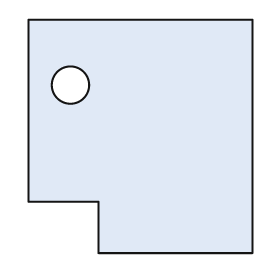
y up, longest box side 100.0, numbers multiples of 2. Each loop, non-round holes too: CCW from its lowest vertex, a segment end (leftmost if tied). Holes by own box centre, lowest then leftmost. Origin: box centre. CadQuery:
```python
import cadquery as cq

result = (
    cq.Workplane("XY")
    .moveTo(-18.0, -50.0)
    .lineTo(48.0, -50.0)
    .lineTo(48.0, 50.0)
    .lineTo(-48.0, 50.0)
    .lineTo(-48.0, -28.0)
    .lineTo(-18.0, -28.0)
    .close()
    .moveTo(-30.0, 22.0)
    .circle(8.0)
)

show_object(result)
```